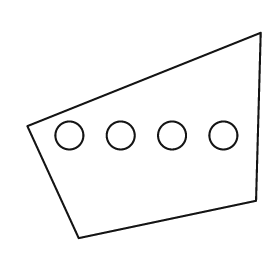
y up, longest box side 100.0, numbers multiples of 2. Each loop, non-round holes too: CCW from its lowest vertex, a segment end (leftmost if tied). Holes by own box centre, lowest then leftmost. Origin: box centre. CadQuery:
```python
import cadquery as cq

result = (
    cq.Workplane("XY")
    .moveTo(-28.0, -44.0)
    .lineTo(48.0, -28.0)
    .lineTo(50.0, 44.0)
    .lineTo(-50.0, 4.0)
    .close()
    .moveTo(-32.0, 0.0)
    .circle(6.0)
    .moveTo(-10.0, 0.0)
    .circle(6.0)
    .moveTo(12.0, 0.0)
    .circle(6.0)
    .moveTo(34.0, 0.0)
    .circle(6.0)
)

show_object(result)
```